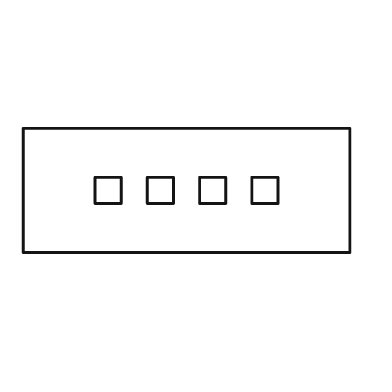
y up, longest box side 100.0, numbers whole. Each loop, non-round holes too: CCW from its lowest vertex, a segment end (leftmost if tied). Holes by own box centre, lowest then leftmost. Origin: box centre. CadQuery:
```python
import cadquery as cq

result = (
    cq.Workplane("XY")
    .moveTo(-50.0, -19.0)
    .lineTo(50.0, -19.0)
    .lineTo(50.0, 19.0)
    .lineTo(-50.0, 19.0)
    .close()
    .moveTo(-28.0, -4.0)
    .lineTo(-20.0, -4.0)
    .lineTo(-20.0, 4.0)
    .lineTo(-28.0, 4.0)
    .close()
    .moveTo(-12.0, -4.0)
    .lineTo(-4.0, -4.0)
    .lineTo(-4.0, 4.0)
    .lineTo(-12.0, 4.0)
    .close()
    .moveTo(4.0, -4.0)
    .lineTo(12.0, -4.0)
    .lineTo(12.0, 4.0)
    .lineTo(4.0, 4.0)
    .close()
    .moveTo(20.0, -4.0)
    .lineTo(28.0, -4.0)
    .lineTo(28.0, 4.0)
    .lineTo(20.0, 4.0)
    .close()
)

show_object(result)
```